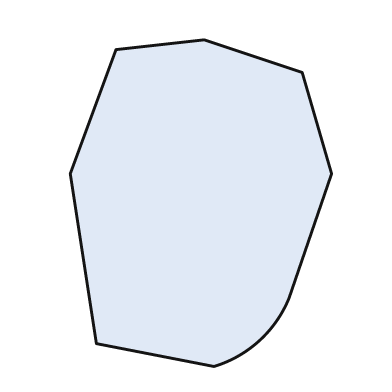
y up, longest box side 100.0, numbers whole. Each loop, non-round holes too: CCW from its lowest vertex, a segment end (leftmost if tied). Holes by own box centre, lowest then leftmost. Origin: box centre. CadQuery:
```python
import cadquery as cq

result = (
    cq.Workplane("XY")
    .moveTo(4.0, -50.0)
    .threePointArc((18.0, -42.0), (27.0, -29.0))
    .lineTo(40.0, 9.0)
    .lineTo(31.0, 40.0)
    .lineTo(1.0, 50.0)
    .lineTo(-26.0, 47.0)
    .lineTo(-40.0, 9.0)
    .lineTo(-32.0, -43.0)
    .close()
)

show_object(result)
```